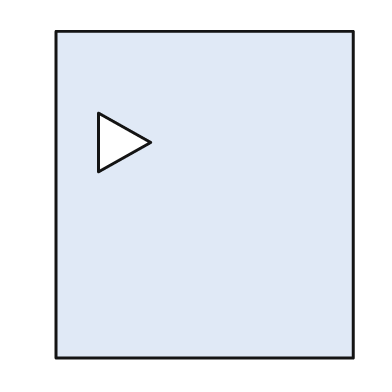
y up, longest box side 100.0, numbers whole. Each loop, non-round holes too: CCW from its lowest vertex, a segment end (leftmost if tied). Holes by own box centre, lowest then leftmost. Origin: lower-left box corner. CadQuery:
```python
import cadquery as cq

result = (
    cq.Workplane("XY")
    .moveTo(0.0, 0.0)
    .lineTo(91.0, 0.0)
    .lineTo(91.0, 100.0)
    .lineTo(0.0, 100.0)
    .close()
    .moveTo(13.0, 57.0)
    .lineTo(29.0, 66.0)
    .lineTo(13.0, 75.0)
    .close()
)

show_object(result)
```